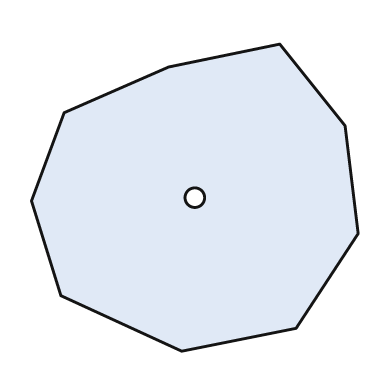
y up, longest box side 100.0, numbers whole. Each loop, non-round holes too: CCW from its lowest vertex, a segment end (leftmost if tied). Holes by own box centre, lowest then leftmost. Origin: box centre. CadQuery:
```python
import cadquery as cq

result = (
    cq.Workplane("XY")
    .moveTo(-4.0, -47.0)
    .lineTo(31.0, -40.0)
    .lineTo(50.0, -11.0)
    .lineTo(46.0, 22.0)
    .lineTo(26.0, 47.0)
    .lineTo(-8.0, 40.0)
    .lineTo(-40.0, 26.0)
    .lineTo(-50.0, -1.0)
    .lineTo(-41.0, -30.0)
    .close()
    .moveTo(0.0, 0.0)
    .circle(3.0)
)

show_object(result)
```